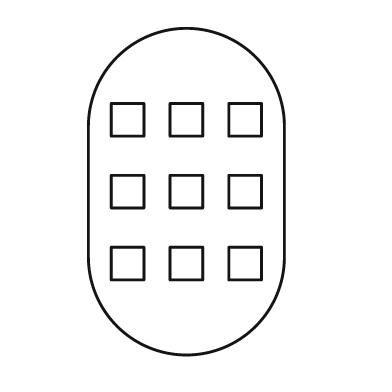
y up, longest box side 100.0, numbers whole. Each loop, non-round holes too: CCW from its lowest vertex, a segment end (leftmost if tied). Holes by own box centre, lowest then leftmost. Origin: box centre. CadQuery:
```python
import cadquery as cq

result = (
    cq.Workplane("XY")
    .moveTo(-30.0, -20.0)
    .threePointArc((0.0, -50.0), (30.0, -20.0))
    .lineTo(30.0, 20.0)
    .threePointArc((0.0, 50.0), (-30.0, 20.0))
    .close()
    .moveTo(-23.0, -27.0)
    .lineTo(-13.0, -27.0)
    .lineTo(-13.0, -17.0)
    .lineTo(-23.0, -17.0)
    .close()
    .moveTo(-5.0, -27.0)
    .lineTo(5.0, -27.0)
    .lineTo(5.0, -17.0)
    .lineTo(-5.0, -17.0)
    .close()
    .moveTo(13.0, -27.0)
    .lineTo(23.0, -27.0)
    .lineTo(23.0, -17.0)
    .lineTo(13.0, -17.0)
    .close()
    .moveTo(-23.0, -5.0)
    .lineTo(-13.0, -5.0)
    .lineTo(-13.0, 5.0)
    .lineTo(-23.0, 5.0)
    .close()
    .moveTo(-5.0, -5.0)
    .lineTo(5.0, -5.0)
    .lineTo(5.0, 5.0)
    .lineTo(-5.0, 5.0)
    .close()
    .moveTo(13.0, -5.0)
    .lineTo(23.0, -5.0)
    .lineTo(23.0, 5.0)
    .lineTo(13.0, 5.0)
    .close()
    .moveTo(-23.0, 17.0)
    .lineTo(-13.0, 17.0)
    .lineTo(-13.0, 27.0)
    .lineTo(-23.0, 27.0)
    .close()
    .moveTo(-5.0, 17.0)
    .lineTo(5.0, 17.0)
    .lineTo(5.0, 27.0)
    .lineTo(-5.0, 27.0)
    .close()
    .moveTo(13.0, 17.0)
    .lineTo(23.0, 17.0)
    .lineTo(23.0, 27.0)
    .lineTo(13.0, 27.0)
    .close()
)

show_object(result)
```